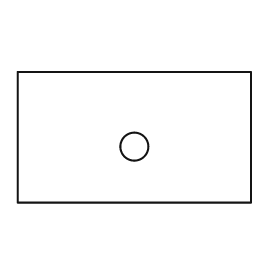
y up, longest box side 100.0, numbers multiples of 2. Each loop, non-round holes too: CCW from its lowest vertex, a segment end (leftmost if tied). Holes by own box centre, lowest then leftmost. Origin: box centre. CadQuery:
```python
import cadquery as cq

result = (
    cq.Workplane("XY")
    .moveTo(-50.0, -28.0)
    .lineTo(50.0, -28.0)
    .lineTo(50.0, 28.0)
    .lineTo(-50.0, 28.0)
    .close()
    .moveTo(0.0, -4.0)
    .circle(6.0)
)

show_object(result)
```